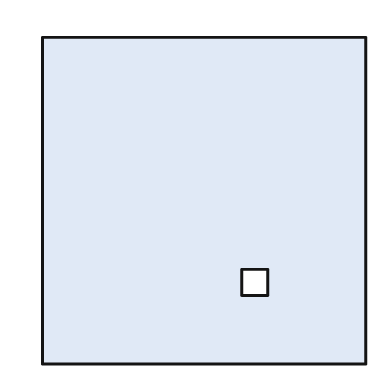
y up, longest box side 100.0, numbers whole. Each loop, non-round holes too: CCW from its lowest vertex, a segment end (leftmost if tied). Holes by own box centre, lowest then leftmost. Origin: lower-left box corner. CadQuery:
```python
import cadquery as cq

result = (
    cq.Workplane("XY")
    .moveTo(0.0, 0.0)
    .lineTo(99.0, 0.0)
    .lineTo(99.0, 100.0)
    .lineTo(0.0, 100.0)
    .close()
    .moveTo(61.0, 21.0)
    .lineTo(69.0, 21.0)
    .lineTo(69.0, 29.0)
    .lineTo(61.0, 29.0)
    .close()
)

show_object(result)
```